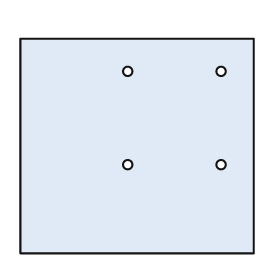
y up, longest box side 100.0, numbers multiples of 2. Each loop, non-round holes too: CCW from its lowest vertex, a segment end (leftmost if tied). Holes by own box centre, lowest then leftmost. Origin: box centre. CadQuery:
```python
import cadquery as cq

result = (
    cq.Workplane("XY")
    .moveTo(-50.0, -46.0)
    .lineTo(50.0, -46.0)
    .lineTo(50.0, 46.0)
    .lineTo(-50.0, 46.0)
    .close()
    .moveTo(-4.0, -8.0)
    .circle(2.0)
    .moveTo(36.0, -8.0)
    .circle(2.0)
    .moveTo(-4.0, 32.0)
    .circle(2.0)
    .moveTo(36.0, 32.0)
    .circle(2.0)
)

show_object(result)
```